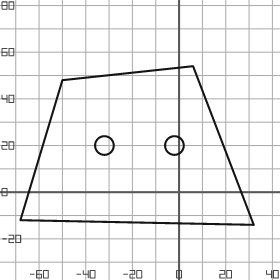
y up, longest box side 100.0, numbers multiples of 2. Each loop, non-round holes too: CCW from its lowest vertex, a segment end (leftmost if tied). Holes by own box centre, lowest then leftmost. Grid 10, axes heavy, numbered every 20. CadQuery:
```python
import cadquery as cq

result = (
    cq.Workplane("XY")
    .moveTo(32.0, -14.0)
    .lineTo(6.0, 54.0)
    .lineTo(-50.0, 48.0)
    .lineTo(-68.0, -12.0)
    .close()
    .moveTo(-32.0, 20.0)
    .circle(4.0)
    .moveTo(-2.0, 20.0)
    .circle(4.0)
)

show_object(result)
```